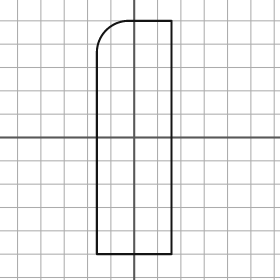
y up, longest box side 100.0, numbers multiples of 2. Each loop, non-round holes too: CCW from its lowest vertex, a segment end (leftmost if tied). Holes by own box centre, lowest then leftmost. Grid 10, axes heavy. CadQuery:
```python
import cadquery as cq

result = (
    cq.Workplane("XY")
    .moveTo(-16.0, -50.0)
    .lineTo(16.0, -50.0)
    .lineTo(16.0, 50.0)
    .lineTo(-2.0, 50.0)
    .threePointArc((-12.0, 46.0), (-16.0, 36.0))
    .close()
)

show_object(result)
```